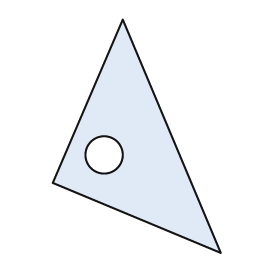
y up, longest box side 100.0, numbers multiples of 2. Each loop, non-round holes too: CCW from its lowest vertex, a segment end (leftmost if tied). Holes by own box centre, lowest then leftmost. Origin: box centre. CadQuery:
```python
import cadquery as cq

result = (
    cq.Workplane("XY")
    .moveTo(36.0, -50.0)
    .lineTo(-6.0, 50.0)
    .lineTo(-36.0, -20.0)
    .close()
    .moveTo(-14.0, -8.0)
    .circle(8.0)
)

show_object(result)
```